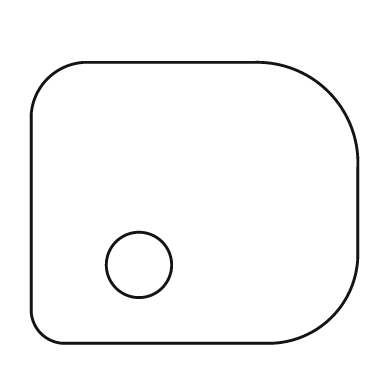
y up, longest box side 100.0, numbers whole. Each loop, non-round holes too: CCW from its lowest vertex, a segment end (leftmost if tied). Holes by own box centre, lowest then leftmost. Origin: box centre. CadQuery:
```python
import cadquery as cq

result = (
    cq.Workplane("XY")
    .moveTo(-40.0, -43.0)
    .lineTo(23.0, -43.0)
    .threePointArc((42.0, -35.0), (50.0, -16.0))
    .lineTo(50.0, 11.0)
    .threePointArc((41.0, 34.0), (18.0, 43.0))
    .lineTo(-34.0, 43.0)
    .threePointArc((-45.0, 38.0), (-50.0, 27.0))
    .lineTo(-50.0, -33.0)
    .threePointArc((-47.0, -40.0), (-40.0, -43.0))
    .close()
    .moveTo(-17.0, -19.0)
    .circle(10.0)
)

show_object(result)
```